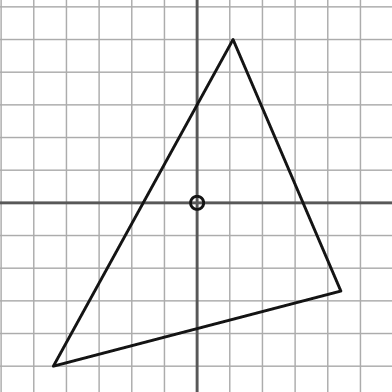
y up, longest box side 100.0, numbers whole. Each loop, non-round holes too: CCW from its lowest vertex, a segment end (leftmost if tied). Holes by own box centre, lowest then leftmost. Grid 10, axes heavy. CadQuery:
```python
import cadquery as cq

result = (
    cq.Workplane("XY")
    .moveTo(-44.0, -50.0)
    .lineTo(44.0, -27.0)
    .lineTo(11.0, 50.0)
    .close()
    .moveTo(0.0, 0.0)
    .circle(2.0)
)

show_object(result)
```